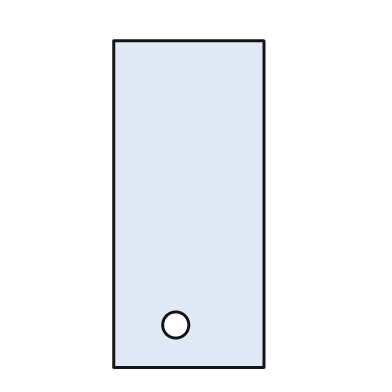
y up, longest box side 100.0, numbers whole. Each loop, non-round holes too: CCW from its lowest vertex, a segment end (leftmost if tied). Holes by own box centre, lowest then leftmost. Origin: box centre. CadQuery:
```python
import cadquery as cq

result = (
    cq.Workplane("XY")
    .moveTo(-23.0, -50.0)
    .lineTo(23.0, -50.0)
    .lineTo(23.0, 50.0)
    .lineTo(-23.0, 50.0)
    .close()
    .moveTo(-4.0, -37.0)
    .circle(4.0)
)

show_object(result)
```